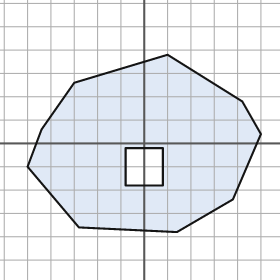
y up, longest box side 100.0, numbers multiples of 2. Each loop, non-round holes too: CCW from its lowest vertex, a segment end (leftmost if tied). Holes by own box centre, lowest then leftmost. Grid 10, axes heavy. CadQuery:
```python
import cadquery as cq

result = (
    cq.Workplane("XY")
    .moveTo(14.0, -38.0)
    .lineTo(38.0, -24.0)
    .lineTo(50.0, 4.0)
    .lineTo(42.0, 18.0)
    .lineTo(10.0, 38.0)
    .lineTo(-30.0, 26.0)
    .lineTo(-44.0, 6.0)
    .lineTo(-50.0, -10.0)
    .lineTo(-28.0, -36.0)
    .close()
    .moveTo(-8.0, -18.0)
    .lineTo(8.0, -18.0)
    .lineTo(8.0, -2.0)
    .lineTo(-8.0, -2.0)
    .close()
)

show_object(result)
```